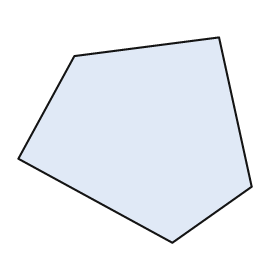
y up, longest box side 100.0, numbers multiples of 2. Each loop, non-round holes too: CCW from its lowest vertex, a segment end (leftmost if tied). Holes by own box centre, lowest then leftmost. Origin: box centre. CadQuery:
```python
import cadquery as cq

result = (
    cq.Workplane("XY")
    .moveTo(16.0, -44.0)
    .lineTo(50.0, -20.0)
    .lineTo(36.0, 44.0)
    .lineTo(-26.0, 36.0)
    .lineTo(-50.0, -8.0)
    .close()
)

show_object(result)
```